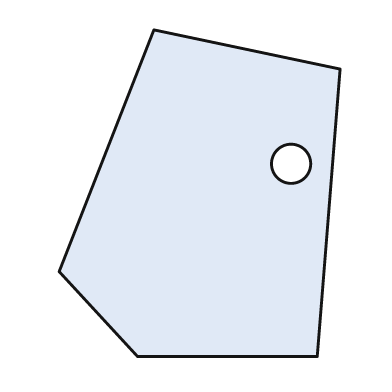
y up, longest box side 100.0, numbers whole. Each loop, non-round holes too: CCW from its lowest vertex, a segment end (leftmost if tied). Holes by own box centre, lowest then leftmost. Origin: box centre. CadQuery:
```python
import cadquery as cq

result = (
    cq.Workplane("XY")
    .moveTo(-19.0, -50.0)
    .lineTo(36.0, -50.0)
    .lineTo(43.0, 38.0)
    .lineTo(-14.0, 50.0)
    .lineTo(-43.0, -24.0)
    .close()
    .moveTo(28.0, 9.0)
    .circle(6.0)
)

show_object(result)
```